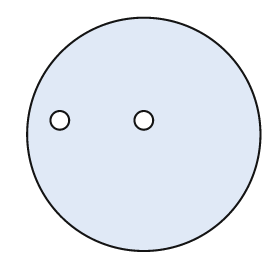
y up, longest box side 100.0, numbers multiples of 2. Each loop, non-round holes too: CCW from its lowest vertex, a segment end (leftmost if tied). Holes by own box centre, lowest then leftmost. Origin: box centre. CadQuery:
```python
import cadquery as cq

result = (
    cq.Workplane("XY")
    .moveTo(0.0, 0.0)
    .circle(50.0)
    .moveTo(-36.0, 6.0)
    .circle(4.0)
    .moveTo(0.0, 6.0)
    .circle(4.0)
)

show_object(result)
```